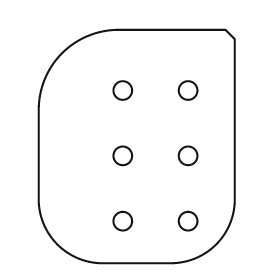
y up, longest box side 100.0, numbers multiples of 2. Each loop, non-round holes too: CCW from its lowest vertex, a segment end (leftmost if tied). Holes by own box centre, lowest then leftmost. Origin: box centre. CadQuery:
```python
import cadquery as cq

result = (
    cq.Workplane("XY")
    .moveTo(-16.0, -50.0)
    .lineTo(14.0, -50.0)
    .threePointArc((34.0, -42.0), (42.0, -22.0))
    .lineTo(42.0, 46.0)
    .lineTo(38.0, 50.0)
    .lineTo(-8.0, 50.0)
    .threePointArc((-32.0, 40.0), (-42.0, 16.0))
    .lineTo(-42.0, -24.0)
    .threePointArc((-34.0, -42.0), (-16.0, -50.0))
    .close()
    .moveTo(-6.0, -32.0)
    .circle(4.0)
    .moveTo(22.0, -32.0)
    .circle(4.0)
    .moveTo(-6.0, -4.0)
    .circle(4.0)
    .moveTo(22.0, -4.0)
    .circle(4.0)
    .moveTo(-6.0, 24.0)
    .circle(4.0)
    .moveTo(22.0, 24.0)
    .circle(4.0)
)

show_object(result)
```